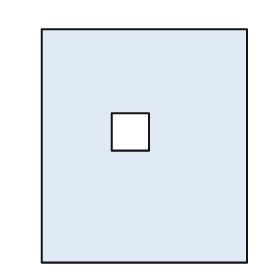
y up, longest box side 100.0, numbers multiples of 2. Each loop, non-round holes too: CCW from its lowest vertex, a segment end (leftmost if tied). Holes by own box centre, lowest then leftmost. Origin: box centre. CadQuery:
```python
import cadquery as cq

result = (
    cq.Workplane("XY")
    .moveTo(-44.0, -50.0)
    .lineTo(44.0, -50.0)
    .lineTo(44.0, 50.0)
    .lineTo(-44.0, 50.0)
    .close()
    .moveTo(-14.0, -2.0)
    .lineTo(2.0, -2.0)
    .lineTo(2.0, 14.0)
    .lineTo(-14.0, 14.0)
    .close()
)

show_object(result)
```